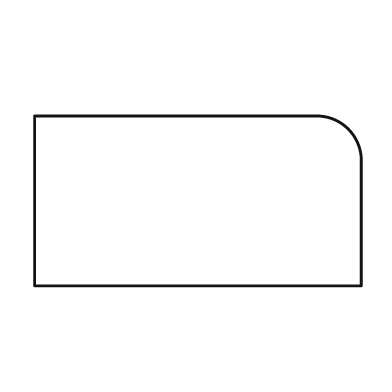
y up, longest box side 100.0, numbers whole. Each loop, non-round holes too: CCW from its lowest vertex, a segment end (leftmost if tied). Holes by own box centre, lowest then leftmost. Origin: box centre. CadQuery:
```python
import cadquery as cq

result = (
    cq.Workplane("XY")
    .moveTo(-50.0, -26.0)
    .lineTo(50.0, -26.0)
    .lineTo(50.0, 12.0)
    .threePointArc((46.0, 22.0), (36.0, 26.0))
    .lineTo(-50.0, 26.0)
    .close()
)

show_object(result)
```